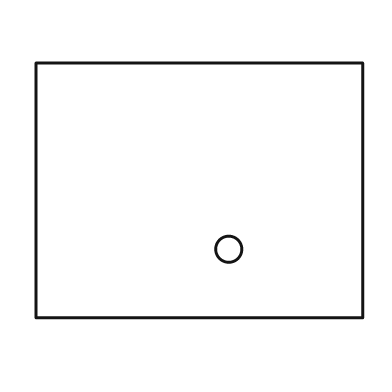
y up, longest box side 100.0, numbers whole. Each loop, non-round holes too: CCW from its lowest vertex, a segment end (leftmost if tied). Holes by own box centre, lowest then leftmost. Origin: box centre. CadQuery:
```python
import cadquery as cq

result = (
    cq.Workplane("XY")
    .moveTo(-50.0, -39.0)
    .lineTo(50.0, -39.0)
    .lineTo(50.0, 39.0)
    .lineTo(-50.0, 39.0)
    .close()
    .moveTo(9.0, -18.0)
    .circle(4.0)
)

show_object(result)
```